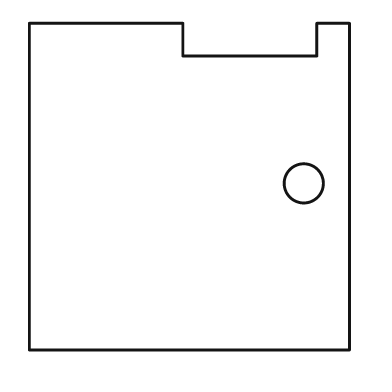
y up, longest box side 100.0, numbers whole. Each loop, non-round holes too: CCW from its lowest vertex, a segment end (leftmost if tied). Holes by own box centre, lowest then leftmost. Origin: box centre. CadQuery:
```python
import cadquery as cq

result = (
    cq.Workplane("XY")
    .moveTo(-49.0, -50.0)
    .lineTo(49.0, -50.0)
    .lineTo(49.0, 50.0)
    .lineTo(39.0, 50.0)
    .lineTo(39.0, 40.0)
    .lineTo(-2.0, 40.0)
    .lineTo(-2.0, 50.0)
    .lineTo(-49.0, 50.0)
    .close()
    .moveTo(35.0, 1.0)
    .circle(6.0)
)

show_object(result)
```